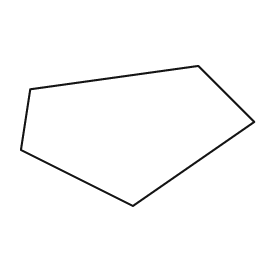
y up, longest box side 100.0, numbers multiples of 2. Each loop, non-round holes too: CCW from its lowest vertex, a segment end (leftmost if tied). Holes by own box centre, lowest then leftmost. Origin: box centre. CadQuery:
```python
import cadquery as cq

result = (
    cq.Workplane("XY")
    .moveTo(-2.0, -30.0)
    .lineTo(50.0, 6.0)
    .lineTo(26.0, 30.0)
    .lineTo(-46.0, 20.0)
    .lineTo(-50.0, -6.0)
    .close()
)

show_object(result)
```